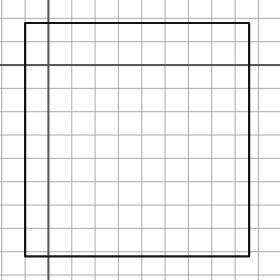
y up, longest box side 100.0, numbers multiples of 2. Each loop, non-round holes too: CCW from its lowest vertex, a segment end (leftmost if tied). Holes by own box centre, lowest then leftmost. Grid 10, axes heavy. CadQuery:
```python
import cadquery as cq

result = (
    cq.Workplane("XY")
    .moveTo(-10.0, -82.0)
    .lineTo(86.0, -82.0)
    .lineTo(86.0, 18.0)
    .lineTo(-10.0, 18.0)
    .close()
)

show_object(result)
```